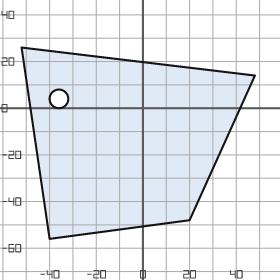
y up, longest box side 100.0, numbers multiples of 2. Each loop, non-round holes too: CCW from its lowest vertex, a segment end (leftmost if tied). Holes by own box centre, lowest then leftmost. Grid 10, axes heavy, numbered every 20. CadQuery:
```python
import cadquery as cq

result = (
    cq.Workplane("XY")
    .moveTo(-40.0, -56.0)
    .lineTo(20.0, -48.0)
    .lineTo(48.0, 14.0)
    .lineTo(-52.0, 26.0)
    .close()
    .moveTo(-36.0, 4.0)
    .circle(4.0)
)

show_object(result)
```